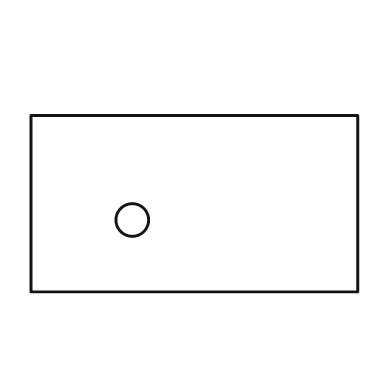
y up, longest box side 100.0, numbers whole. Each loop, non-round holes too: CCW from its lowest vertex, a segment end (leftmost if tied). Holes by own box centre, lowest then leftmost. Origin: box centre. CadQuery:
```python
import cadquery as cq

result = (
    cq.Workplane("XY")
    .moveTo(-50.0, -27.0)
    .lineTo(50.0, -27.0)
    .lineTo(50.0, 27.0)
    .lineTo(-50.0, 27.0)
    .close()
    .moveTo(-19.0, -5.0)
    .circle(5.0)
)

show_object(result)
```